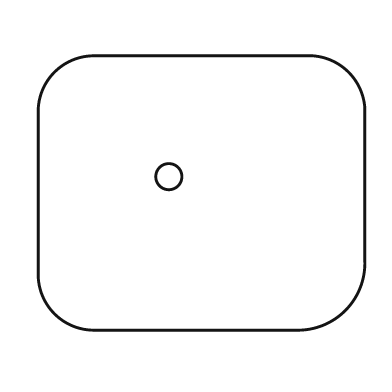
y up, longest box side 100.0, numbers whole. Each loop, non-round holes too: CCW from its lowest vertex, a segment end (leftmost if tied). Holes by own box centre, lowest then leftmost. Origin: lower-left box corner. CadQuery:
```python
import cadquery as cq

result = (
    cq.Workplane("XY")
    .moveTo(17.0, 0.0)
    .lineTo(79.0, 0.0)
    .threePointArc((94.0, 6.0), (100.0, 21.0))
    .lineTo(100.0, 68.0)
    .threePointArc((95.0, 79.0), (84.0, 84.0))
    .lineTo(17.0, 84.0)
    .threePointArc((5.0, 79.0), (0.0, 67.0))
    .lineTo(0.0, 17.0)
    .threePointArc((5.0, 5.0), (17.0, 0.0))
    .close()
    .moveTo(40.0, 47.0)
    .circle(4.0)
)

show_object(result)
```